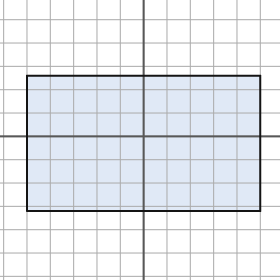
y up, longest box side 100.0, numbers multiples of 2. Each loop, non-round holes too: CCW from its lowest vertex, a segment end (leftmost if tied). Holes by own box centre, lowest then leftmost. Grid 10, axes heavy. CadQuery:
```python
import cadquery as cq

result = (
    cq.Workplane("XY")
    .moveTo(-50.0, -32.0)
    .lineTo(50.0, -32.0)
    .lineTo(50.0, 26.0)
    .lineTo(-50.0, 26.0)
    .close()
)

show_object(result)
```